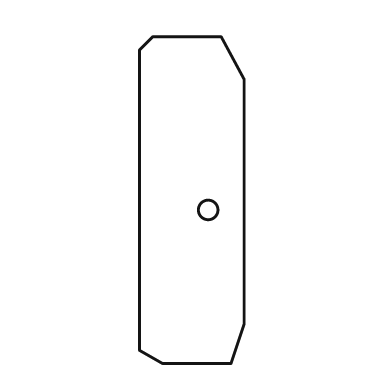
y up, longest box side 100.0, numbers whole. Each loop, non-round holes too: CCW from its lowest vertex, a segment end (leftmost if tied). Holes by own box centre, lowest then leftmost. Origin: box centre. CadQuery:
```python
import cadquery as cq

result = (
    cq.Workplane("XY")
    .moveTo(-9.0, -50.0)
    .lineTo(12.0, -50.0)
    .lineTo(16.0, -38.0)
    .lineTo(16.0, 37.0)
    .lineTo(9.0, 50.0)
    .lineTo(-12.0, 50.0)
    .lineTo(-16.0, 46.0)
    .lineTo(-16.0, -46.0)
    .close()
    .moveTo(5.0, -3.0)
    .circle(3.0)
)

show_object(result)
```